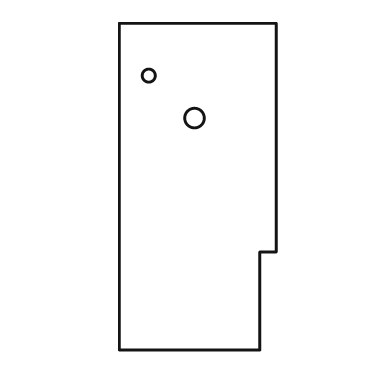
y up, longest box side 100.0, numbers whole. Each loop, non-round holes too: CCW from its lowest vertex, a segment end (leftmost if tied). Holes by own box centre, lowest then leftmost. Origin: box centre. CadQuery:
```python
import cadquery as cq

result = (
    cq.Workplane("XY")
    .moveTo(-24.0, -50.0)
    .lineTo(19.0, -50.0)
    .lineTo(19.0, -20.0)
    .lineTo(24.0, -20.0)
    .lineTo(24.0, 50.0)
    .lineTo(-24.0, 50.0)
    .close()
    .moveTo(-1.0, 21.0)
    .circle(3.0)
    .moveTo(-15.0, 34.0)
    .circle(2.0)
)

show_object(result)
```